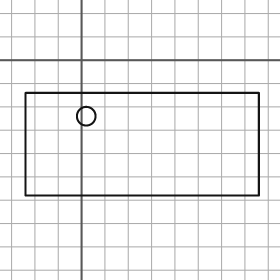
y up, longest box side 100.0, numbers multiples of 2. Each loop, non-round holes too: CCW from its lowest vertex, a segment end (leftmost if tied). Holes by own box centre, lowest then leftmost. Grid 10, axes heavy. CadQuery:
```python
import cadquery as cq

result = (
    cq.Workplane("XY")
    .moveTo(-24.0, -58.0)
    .lineTo(76.0, -58.0)
    .lineTo(76.0, -14.0)
    .lineTo(-24.0, -14.0)
    .close()
    .moveTo(2.0, -24.0)
    .circle(4.0)
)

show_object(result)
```